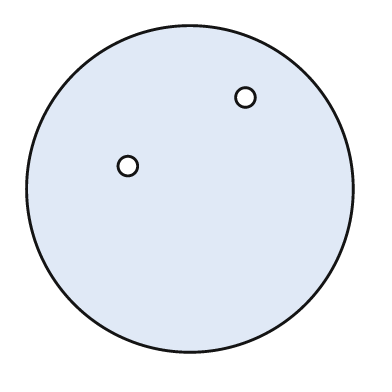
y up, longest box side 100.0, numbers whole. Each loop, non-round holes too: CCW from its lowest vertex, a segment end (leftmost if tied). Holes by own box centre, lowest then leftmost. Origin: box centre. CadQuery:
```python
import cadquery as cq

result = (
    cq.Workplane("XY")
    .moveTo(0.0, 0.0)
    .circle(50.0)
    .moveTo(-19.0, 7.0)
    .circle(3.0)
    .moveTo(17.0, 28.0)
    .circle(3.0)
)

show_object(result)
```